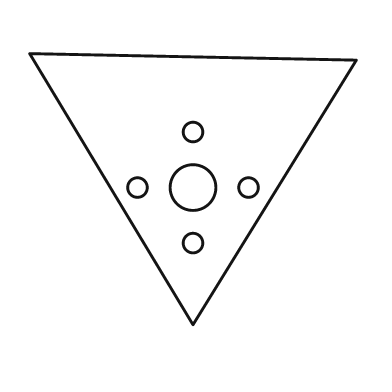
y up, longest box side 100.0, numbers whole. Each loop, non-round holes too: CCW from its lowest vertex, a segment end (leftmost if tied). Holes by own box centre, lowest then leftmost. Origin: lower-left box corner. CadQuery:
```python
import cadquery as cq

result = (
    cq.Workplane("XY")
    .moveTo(50.0, 0.0)
    .lineTo(100.0, 81.0)
    .lineTo(0.0, 83.0)
    .close()
    .moveTo(50.0, 25.0)
    .circle(3.0)
    .moveTo(33.0, 42.0)
    .circle(3.0)
    .moveTo(50.0, 42.0)
    .circle(7.0)
    .moveTo(67.0, 42.0)
    .circle(3.0)
    .moveTo(50.0, 59.0)
    .circle(3.0)
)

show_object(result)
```